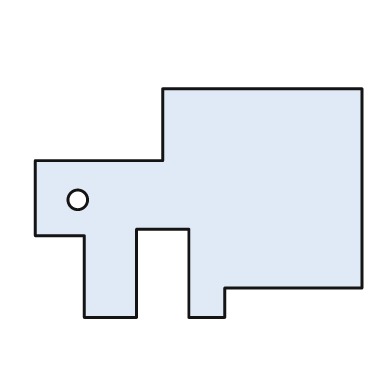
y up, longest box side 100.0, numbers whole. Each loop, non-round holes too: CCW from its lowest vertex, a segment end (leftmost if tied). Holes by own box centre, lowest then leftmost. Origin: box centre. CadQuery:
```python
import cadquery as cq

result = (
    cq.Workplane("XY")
    .moveTo(-35.0, -35.0)
    .lineTo(-19.0, -35.0)
    .lineTo(-19.0, -8.0)
    .lineTo(-3.0, -8.0)
    .lineTo(-3.0, -35.0)
    .lineTo(8.0, -35.0)
    .lineTo(8.0, -26.0)
    .lineTo(50.0, -26.0)
    .lineTo(50.0, 35.0)
    .lineTo(-11.0, 35.0)
    .lineTo(-11.0, 13.0)
    .lineTo(-50.0, 13.0)
    .lineTo(-50.0, -10.0)
    .lineTo(-35.0, -10.0)
    .close()
    .moveTo(-37.0, 1.0)
    .circle(3.0)
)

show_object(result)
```